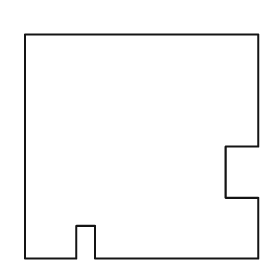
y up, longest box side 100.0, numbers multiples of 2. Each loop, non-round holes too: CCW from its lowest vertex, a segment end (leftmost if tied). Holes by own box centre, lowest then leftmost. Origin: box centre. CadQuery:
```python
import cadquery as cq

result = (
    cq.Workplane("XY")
    .moveTo(-50.0, -48.0)
    .lineTo(-28.0, -48.0)
    .lineTo(-28.0, -34.0)
    .lineTo(-20.0, -34.0)
    .lineTo(-20.0, -48.0)
    .lineTo(50.0, -48.0)
    .lineTo(50.0, -22.0)
    .lineTo(36.0, -22.0)
    .lineTo(36.0, 0.0)
    .lineTo(50.0, 0.0)
    .lineTo(50.0, 48.0)
    .lineTo(-50.0, 48.0)
    .close()
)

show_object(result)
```